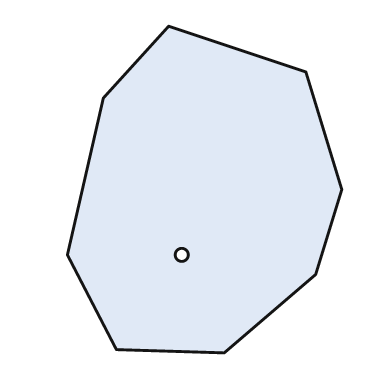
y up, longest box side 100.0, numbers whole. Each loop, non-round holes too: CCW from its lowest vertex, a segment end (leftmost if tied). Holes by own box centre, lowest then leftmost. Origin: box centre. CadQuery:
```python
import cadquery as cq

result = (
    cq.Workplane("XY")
    .moveTo(6.0, -50.0)
    .lineTo(34.0, -26.0)
    .lineTo(42.0, 0.0)
    .lineTo(31.0, 36.0)
    .lineTo(-11.0, 50.0)
    .lineTo(-31.0, 28.0)
    .lineTo(-42.0, -20.0)
    .lineTo(-27.0, -49.0)
    .close()
    .moveTo(-7.0, -20.0)
    .circle(2.0)
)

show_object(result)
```